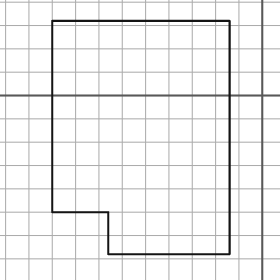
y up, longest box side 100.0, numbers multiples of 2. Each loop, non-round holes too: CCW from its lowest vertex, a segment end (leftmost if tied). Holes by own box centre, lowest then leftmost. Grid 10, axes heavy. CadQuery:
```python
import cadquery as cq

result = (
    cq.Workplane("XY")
    .moveTo(-66.0, -68.0)
    .lineTo(-14.0, -68.0)
    .lineTo(-14.0, 32.0)
    .lineTo(-90.0, 32.0)
    .lineTo(-90.0, -50.0)
    .lineTo(-66.0, -50.0)
    .close()
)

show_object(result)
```